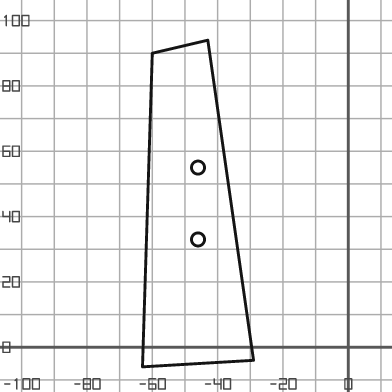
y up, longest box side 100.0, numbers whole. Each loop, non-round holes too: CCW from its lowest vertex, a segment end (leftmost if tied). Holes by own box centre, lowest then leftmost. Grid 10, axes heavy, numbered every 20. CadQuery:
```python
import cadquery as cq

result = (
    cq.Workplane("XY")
    .moveTo(-63.0, -6.0)
    .lineTo(-29.0, -4.0)
    .lineTo(-43.0, 94.0)
    .lineTo(-60.0, 90.0)
    .close()
    .moveTo(-46.0, 33.0)
    .circle(2.0)
    .moveTo(-46.0, 55.0)
    .circle(2.0)
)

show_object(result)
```